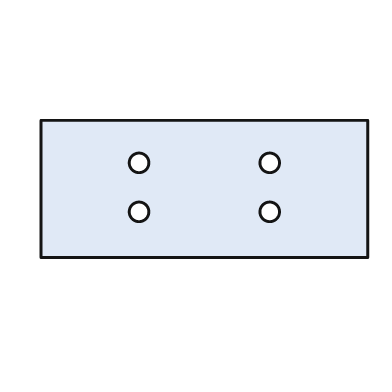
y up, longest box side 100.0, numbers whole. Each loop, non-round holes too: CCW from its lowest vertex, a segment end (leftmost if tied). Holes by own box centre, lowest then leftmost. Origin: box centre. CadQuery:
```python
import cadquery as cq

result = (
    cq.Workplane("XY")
    .moveTo(-50.0, -21.0)
    .lineTo(50.0, -21.0)
    .lineTo(50.0, 21.0)
    .lineTo(-50.0, 21.0)
    .close()
    .moveTo(-20.0, -7.0)
    .circle(3.0)
    .moveTo(20.0, -7.0)
    .circle(3.0)
    .moveTo(-20.0, 8.0)
    .circle(3.0)
    .moveTo(20.0, 8.0)
    .circle(3.0)
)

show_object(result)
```